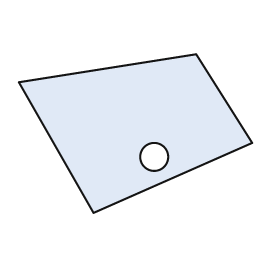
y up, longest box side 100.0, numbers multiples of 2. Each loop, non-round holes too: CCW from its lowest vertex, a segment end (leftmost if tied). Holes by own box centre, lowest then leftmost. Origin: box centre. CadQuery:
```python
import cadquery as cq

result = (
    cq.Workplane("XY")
    .moveTo(-18.0, -34.0)
    .lineTo(50.0, -4.0)
    .lineTo(26.0, 34.0)
    .lineTo(-50.0, 22.0)
    .close()
    .moveTo(8.0, -10.0)
    .circle(6.0)
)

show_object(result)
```